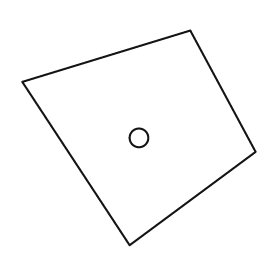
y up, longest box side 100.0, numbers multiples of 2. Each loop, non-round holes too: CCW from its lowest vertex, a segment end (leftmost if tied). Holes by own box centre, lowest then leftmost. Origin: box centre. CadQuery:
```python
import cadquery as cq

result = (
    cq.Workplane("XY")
    .moveTo(-4.0, -46.0)
    .lineTo(50.0, -6.0)
    .lineTo(22.0, 46.0)
    .lineTo(-50.0, 24.0)
    .close()
    .moveTo(0.0, 0.0)
    .circle(4.0)
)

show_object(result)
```